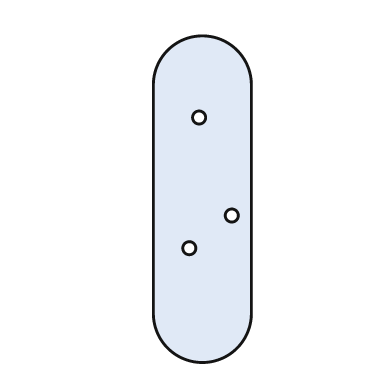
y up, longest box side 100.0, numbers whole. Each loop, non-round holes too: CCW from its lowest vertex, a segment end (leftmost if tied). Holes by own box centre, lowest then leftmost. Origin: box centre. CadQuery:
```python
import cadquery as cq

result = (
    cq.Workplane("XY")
    .moveTo(-15.0, -35.0)
    .threePointArc((0.0, -50.0), (15.0, -35.0))
    .lineTo(15.0, 35.0)
    .threePointArc((0.0, 50.0), (-15.0, 35.0))
    .close()
    .moveTo(-4.0, -15.0)
    .circle(2.0)
    .moveTo(9.0, -5.0)
    .circle(2.0)
    .moveTo(-1.0, 25.0)
    .circle(2.0)
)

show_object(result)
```